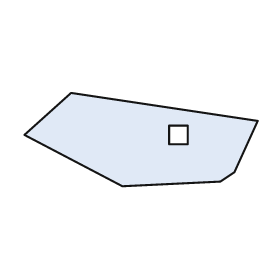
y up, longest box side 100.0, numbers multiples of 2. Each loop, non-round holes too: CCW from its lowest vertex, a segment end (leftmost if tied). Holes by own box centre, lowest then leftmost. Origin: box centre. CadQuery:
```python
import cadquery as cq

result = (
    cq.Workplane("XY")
    .moveTo(-8.0, -20.0)
    .lineTo(34.0, -18.0)
    .lineTo(40.0, -14.0)
    .lineTo(50.0, 8.0)
    .lineTo(-30.0, 20.0)
    .lineTo(-50.0, 2.0)
    .close()
    .moveTo(12.0, -2.0)
    .lineTo(20.0, -2.0)
    .lineTo(20.0, 6.0)
    .lineTo(12.0, 6.0)
    .close()
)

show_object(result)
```